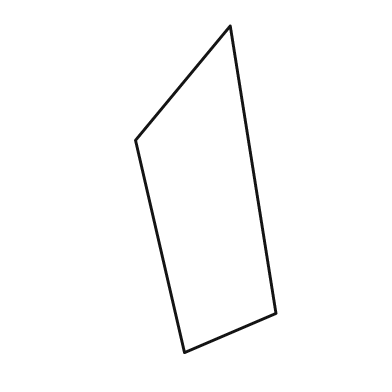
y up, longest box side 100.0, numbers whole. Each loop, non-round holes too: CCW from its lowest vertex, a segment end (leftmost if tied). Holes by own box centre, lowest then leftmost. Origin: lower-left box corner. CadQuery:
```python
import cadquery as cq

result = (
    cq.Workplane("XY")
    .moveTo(15.0, 0.0)
    .lineTo(43.0, 12.0)
    .lineTo(29.0, 100.0)
    .lineTo(0.0, 65.0)
    .close()
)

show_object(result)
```